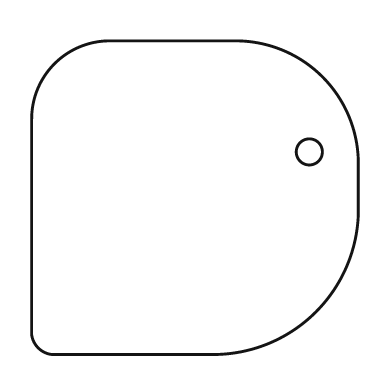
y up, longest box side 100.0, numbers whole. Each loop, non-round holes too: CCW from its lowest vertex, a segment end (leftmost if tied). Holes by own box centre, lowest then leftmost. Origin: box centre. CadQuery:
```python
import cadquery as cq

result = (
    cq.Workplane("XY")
    .moveTo(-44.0, -48.0)
    .lineTo(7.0, -48.0)
    .threePointArc((37.0, -35.0), (50.0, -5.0))
    .lineTo(50.0, 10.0)
    .threePointArc((39.0, 37.0), (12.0, 48.0))
    .lineTo(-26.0, 48.0)
    .threePointArc((-43.0, 41.0), (-50.0, 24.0))
    .lineTo(-50.0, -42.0)
    .threePointArc((-48.0, -46.0), (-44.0, -48.0))
    .close()
    .moveTo(35.0, 14.0)
    .circle(4.0)
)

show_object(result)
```